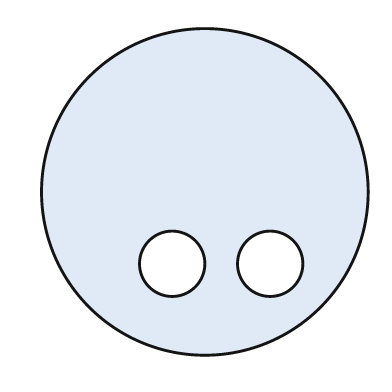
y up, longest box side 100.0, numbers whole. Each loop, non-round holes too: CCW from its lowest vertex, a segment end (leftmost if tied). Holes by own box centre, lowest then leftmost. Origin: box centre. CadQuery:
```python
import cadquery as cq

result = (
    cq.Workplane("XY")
    .moveTo(0.0, 0.0)
    .circle(50.0)
    .moveTo(-10.0, -22.0)
    .circle(10.0)
    .moveTo(20.0, -22.0)
    .circle(10.0)
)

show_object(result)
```